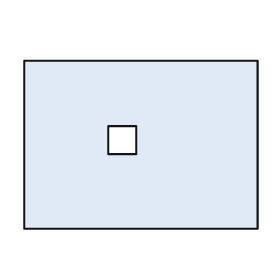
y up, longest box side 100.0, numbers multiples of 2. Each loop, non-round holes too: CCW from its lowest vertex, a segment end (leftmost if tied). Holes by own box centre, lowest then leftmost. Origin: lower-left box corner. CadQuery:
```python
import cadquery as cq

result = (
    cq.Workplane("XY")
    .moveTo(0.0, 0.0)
    .lineTo(100.0, 0.0)
    .lineTo(100.0, 72.0)
    .lineTo(0.0, 72.0)
    .close()
    .moveTo(36.0, 32.0)
    .lineTo(48.0, 32.0)
    .lineTo(48.0, 44.0)
    .lineTo(36.0, 44.0)
    .close()
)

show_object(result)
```